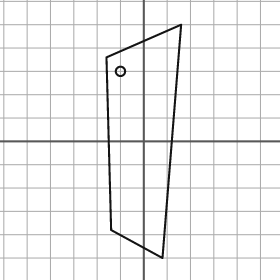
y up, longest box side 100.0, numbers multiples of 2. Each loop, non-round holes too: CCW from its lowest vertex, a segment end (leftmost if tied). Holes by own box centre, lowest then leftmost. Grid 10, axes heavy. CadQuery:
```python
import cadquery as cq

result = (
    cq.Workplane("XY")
    .moveTo(8.0, -50.0)
    .lineTo(16.0, 50.0)
    .lineTo(-16.0, 36.0)
    .lineTo(-14.0, -38.0)
    .close()
    .moveTo(-10.0, 30.0)
    .circle(2.0)
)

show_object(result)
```